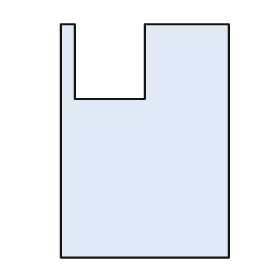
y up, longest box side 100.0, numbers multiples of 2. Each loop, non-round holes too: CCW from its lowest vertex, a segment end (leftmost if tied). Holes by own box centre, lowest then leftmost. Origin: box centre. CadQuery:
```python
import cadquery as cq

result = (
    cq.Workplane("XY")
    .moveTo(-36.0, -50.0)
    .lineTo(36.0, -50.0)
    .lineTo(36.0, 50.0)
    .lineTo(0.0, 50.0)
    .lineTo(0.0, 18.0)
    .lineTo(-30.0, 18.0)
    .lineTo(-30.0, 50.0)
    .lineTo(-36.0, 50.0)
    .close()
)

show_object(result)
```